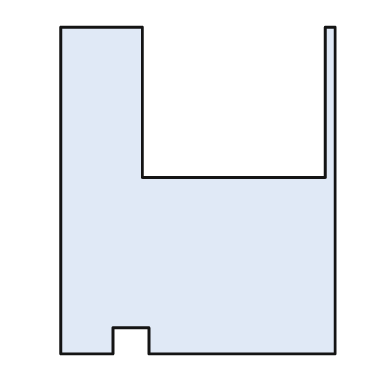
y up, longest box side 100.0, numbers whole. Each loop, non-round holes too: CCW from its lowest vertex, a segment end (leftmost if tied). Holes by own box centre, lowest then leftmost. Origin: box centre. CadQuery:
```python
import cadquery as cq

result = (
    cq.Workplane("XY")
    .moveTo(-42.0, -50.0)
    .lineTo(-26.0, -50.0)
    .lineTo(-26.0, -42.0)
    .lineTo(-15.0, -42.0)
    .lineTo(-15.0, -50.0)
    .lineTo(42.0, -50.0)
    .lineTo(42.0, 50.0)
    .lineTo(39.0, 50.0)
    .lineTo(39.0, 4.0)
    .lineTo(-17.0, 4.0)
    .lineTo(-17.0, 50.0)
    .lineTo(-42.0, 50.0)
    .close()
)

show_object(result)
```